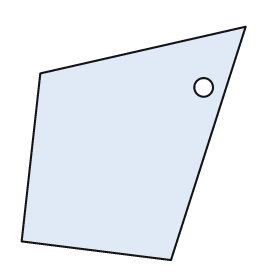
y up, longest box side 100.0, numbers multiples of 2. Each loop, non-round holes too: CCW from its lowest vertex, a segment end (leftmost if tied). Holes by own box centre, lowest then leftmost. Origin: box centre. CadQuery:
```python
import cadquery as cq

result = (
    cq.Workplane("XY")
    .moveTo(16.0, -50.0)
    .lineTo(48.0, 50.0)
    .lineTo(-40.0, 30.0)
    .lineTo(-48.0, -42.0)
    .close()
    .moveTo(30.0, 24.0)
    .circle(4.0)
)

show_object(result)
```